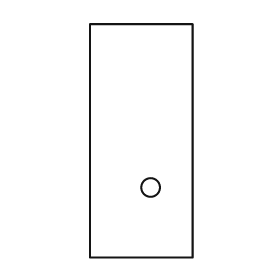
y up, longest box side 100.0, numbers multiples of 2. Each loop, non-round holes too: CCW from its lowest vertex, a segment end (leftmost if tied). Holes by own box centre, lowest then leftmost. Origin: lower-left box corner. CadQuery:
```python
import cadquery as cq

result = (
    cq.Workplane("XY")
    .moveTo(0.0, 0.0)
    .lineTo(44.0, 0.0)
    .lineTo(44.0, 100.0)
    .lineTo(0.0, 100.0)
    .close()
    .moveTo(26.0, 30.0)
    .circle(4.0)
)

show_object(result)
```